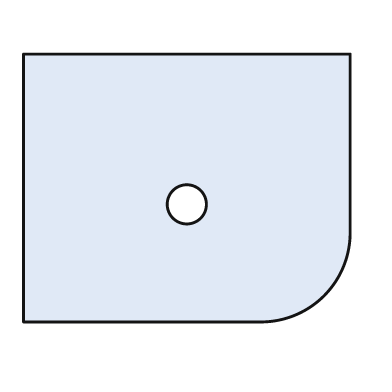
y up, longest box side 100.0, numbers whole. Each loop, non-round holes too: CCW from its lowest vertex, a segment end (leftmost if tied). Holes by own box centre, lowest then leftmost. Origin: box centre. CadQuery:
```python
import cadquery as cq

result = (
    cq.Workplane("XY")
    .moveTo(-50.0, -41.0)
    .lineTo(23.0, -41.0)
    .threePointArc((42.0, -33.0), (50.0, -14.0))
    .lineTo(50.0, 41.0)
    .lineTo(-50.0, 41.0)
    .close()
    .moveTo(0.0, -5.0)
    .circle(6.0)
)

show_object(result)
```